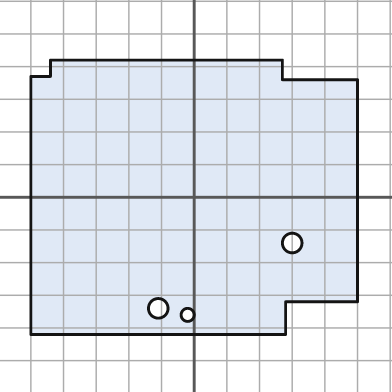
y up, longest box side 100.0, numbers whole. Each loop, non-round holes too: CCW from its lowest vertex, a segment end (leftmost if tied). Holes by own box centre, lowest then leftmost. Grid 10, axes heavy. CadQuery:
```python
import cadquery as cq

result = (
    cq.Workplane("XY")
    .moveTo(-50.0, -42.0)
    .lineTo(28.0, -42.0)
    .lineTo(28.0, -32.0)
    .lineTo(50.0, -32.0)
    .lineTo(50.0, 36.0)
    .lineTo(27.0, 36.0)
    .lineTo(27.0, 42.0)
    .lineTo(-44.0, 42.0)
    .lineTo(-44.0, 37.0)
    .lineTo(-50.0, 37.0)
    .close()
    .moveTo(-2.0, -36.0)
    .circle(2.0)
    .moveTo(-11.0, -34.0)
    .circle(3.0)
    .moveTo(30.0, -14.0)
    .circle(3.0)
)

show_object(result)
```